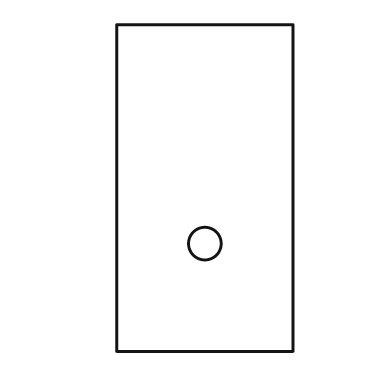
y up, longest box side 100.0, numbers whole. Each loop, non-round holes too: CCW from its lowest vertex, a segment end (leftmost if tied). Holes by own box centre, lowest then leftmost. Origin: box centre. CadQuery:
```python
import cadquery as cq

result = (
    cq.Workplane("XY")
    .moveTo(-27.0, -50.0)
    .lineTo(27.0, -50.0)
    .lineTo(27.0, 50.0)
    .lineTo(-27.0, 50.0)
    .close()
    .moveTo(0.0, -17.0)
    .circle(5.0)
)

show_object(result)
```